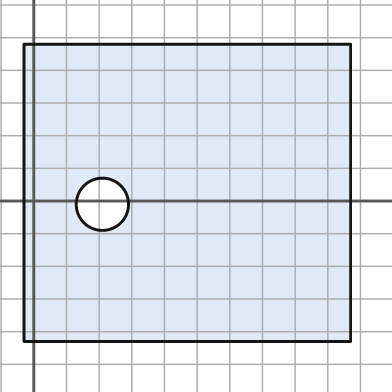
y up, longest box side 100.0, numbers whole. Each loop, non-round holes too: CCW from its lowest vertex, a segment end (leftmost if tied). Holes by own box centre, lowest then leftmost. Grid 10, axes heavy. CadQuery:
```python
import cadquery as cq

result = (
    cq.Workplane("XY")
    .moveTo(-3.0, -43.0)
    .lineTo(97.0, -43.0)
    .lineTo(97.0, 48.0)
    .lineTo(-3.0, 48.0)
    .close()
    .moveTo(21.0, -1.0)
    .circle(8.0)
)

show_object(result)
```